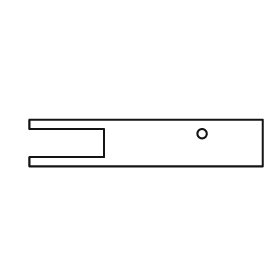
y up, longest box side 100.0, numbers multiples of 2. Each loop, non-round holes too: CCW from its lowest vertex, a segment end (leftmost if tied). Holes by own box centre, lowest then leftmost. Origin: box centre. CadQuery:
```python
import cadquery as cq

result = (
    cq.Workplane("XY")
    .moveTo(-50.0, -10.0)
    .lineTo(50.0, -10.0)
    .lineTo(50.0, 10.0)
    .lineTo(-50.0, 10.0)
    .lineTo(-50.0, 6.0)
    .lineTo(-18.0, 6.0)
    .lineTo(-18.0, -6.0)
    .lineTo(-50.0, -6.0)
    .close()
    .moveTo(24.0, 4.0)
    .circle(2.0)
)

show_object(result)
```